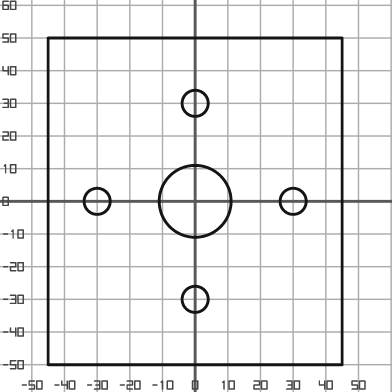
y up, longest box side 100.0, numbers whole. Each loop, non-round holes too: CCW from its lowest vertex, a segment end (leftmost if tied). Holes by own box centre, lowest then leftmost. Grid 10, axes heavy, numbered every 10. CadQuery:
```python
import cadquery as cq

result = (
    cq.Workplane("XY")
    .moveTo(-45.0, -50.0)
    .lineTo(45.0, -50.0)
    .lineTo(45.0, 50.0)
    .lineTo(-45.0, 50.0)
    .close()
    .moveTo(0.0, -30.0)
    .circle(4.0)
    .moveTo(-30.0, 0.0)
    .circle(4.0)
    .moveTo(0.0, 0.0)
    .circle(11.0)
    .moveTo(30.0, 0.0)
    .circle(4.0)
    .moveTo(0.0, 30.0)
    .circle(4.0)
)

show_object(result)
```